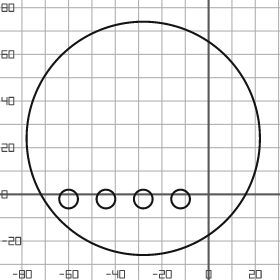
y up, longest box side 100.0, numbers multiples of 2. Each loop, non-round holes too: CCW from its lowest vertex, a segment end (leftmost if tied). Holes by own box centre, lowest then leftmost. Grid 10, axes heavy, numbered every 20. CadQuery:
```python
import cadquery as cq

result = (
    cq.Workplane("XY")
    .moveTo(-28.0, 24.0)
    .circle(50.0)
    .moveTo(-60.0, -2.0)
    .circle(4.0)
    .moveTo(-44.0, -2.0)
    .circle(4.0)
    .moveTo(-28.0, -2.0)
    .circle(4.0)
    .moveTo(-12.0, -2.0)
    .circle(4.0)
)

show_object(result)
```